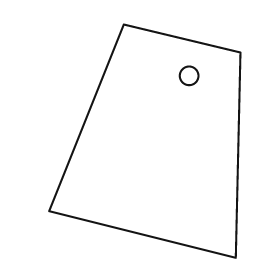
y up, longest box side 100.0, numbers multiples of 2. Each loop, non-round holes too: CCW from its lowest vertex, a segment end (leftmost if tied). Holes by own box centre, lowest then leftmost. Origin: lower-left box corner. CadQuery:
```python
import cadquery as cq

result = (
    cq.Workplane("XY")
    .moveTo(80.0, 0.0)
    .lineTo(82.0, 88.0)
    .lineTo(32.0, 100.0)
    .lineTo(0.0, 20.0)
    .close()
    .moveTo(60.0, 78.0)
    .circle(4.0)
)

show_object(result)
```